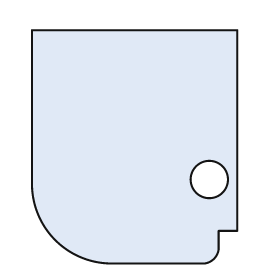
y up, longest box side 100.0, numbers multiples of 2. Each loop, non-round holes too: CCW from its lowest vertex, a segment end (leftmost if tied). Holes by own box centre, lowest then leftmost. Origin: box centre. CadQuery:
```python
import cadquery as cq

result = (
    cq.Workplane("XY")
    .moveTo(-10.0, -50.0)
    .lineTo(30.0, -50.0)
    .threePointArc((34.0, -48.0), (36.0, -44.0))
    .lineTo(36.0, -36.0)
    .lineTo(44.0, -36.0)
    .lineTo(44.0, 50.0)
    .lineTo(-44.0, 50.0)
    .lineTo(-44.0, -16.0)
    .threePointArc((-34.0, -40.0), (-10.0, -50.0))
    .close()
    .moveTo(32.0, -14.0)
    .circle(8.0)
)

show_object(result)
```